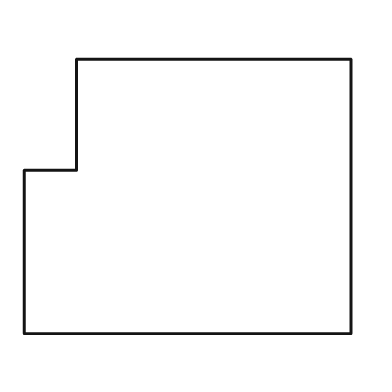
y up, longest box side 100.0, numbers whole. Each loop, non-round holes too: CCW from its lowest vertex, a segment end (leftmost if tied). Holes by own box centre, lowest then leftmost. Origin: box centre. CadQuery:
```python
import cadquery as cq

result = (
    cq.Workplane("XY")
    .moveTo(-50.0, -42.0)
    .lineTo(50.0, -42.0)
    .lineTo(50.0, 42.0)
    .lineTo(-34.0, 42.0)
    .lineTo(-34.0, 8.0)
    .lineTo(-50.0, 8.0)
    .close()
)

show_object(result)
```